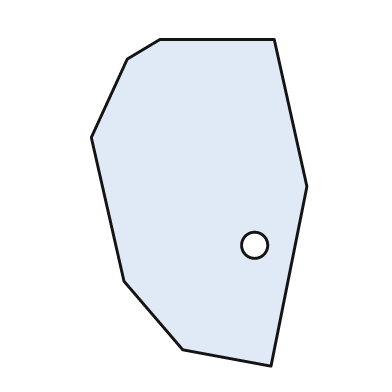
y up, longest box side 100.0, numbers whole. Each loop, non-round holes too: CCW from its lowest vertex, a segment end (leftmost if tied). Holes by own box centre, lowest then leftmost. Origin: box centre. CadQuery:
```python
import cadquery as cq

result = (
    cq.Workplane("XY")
    .moveTo(22.0, -50.0)
    .lineTo(33.0, 5.0)
    .lineTo(23.0, 50.0)
    .lineTo(-12.0, 50.0)
    .lineTo(-22.0, 44.0)
    .lineTo(-33.0, 20.0)
    .lineTo(-23.0, -24.0)
    .lineTo(-5.0, -45.0)
    .close()
    .moveTo(17.0, -13.0)
    .circle(4.0)
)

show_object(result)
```